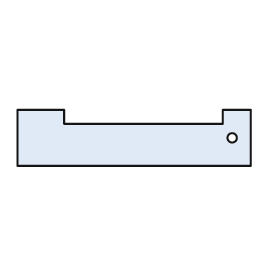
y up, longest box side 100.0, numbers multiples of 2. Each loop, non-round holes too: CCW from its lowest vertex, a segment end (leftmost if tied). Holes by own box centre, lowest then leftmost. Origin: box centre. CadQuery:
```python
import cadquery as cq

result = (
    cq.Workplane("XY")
    .moveTo(-50.0, -12.0)
    .lineTo(50.0, -12.0)
    .lineTo(50.0, 12.0)
    .lineTo(38.0, 12.0)
    .lineTo(38.0, 6.0)
    .lineTo(-30.0, 6.0)
    .lineTo(-30.0, 12.0)
    .lineTo(-50.0, 12.0)
    .close()
    .moveTo(42.0, 0.0)
    .circle(2.0)
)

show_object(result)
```